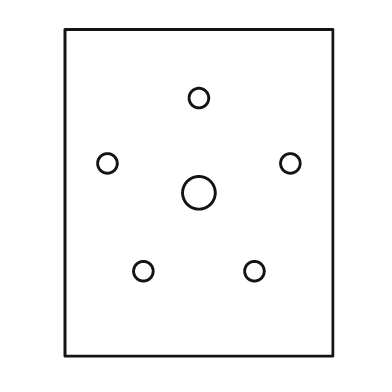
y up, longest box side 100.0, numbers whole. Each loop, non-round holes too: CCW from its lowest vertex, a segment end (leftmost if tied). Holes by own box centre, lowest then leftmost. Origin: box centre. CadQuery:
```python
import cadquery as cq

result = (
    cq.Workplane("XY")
    .moveTo(-41.0, -50.0)
    .lineTo(41.0, -50.0)
    .lineTo(41.0, 50.0)
    .lineTo(-41.0, 50.0)
    .close()
    .moveTo(-17.0, -24.0)
    .circle(3.0)
    .moveTo(17.0, -24.0)
    .circle(3.0)
    .moveTo(0.0, 0.0)
    .circle(5.0)
    .moveTo(-28.0, 9.0)
    .circle(3.0)
    .moveTo(28.0, 9.0)
    .circle(3.0)
    .moveTo(0.0, 29.0)
    .circle(3.0)
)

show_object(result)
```